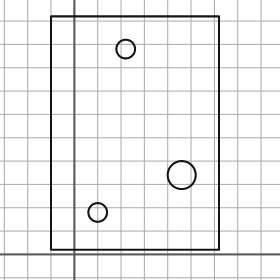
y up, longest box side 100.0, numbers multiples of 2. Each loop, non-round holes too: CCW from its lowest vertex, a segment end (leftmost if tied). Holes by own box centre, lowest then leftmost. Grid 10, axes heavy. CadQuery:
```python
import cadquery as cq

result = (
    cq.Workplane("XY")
    .moveTo(-10.0, 2.0)
    .lineTo(62.0, 2.0)
    .lineTo(62.0, 102.0)
    .lineTo(-10.0, 102.0)
    .close()
    .moveTo(10.0, 18.0)
    .circle(4.0)
    .moveTo(46.0, 34.0)
    .circle(6.0)
    .moveTo(22.0, 88.0)
    .circle(4.0)
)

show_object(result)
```